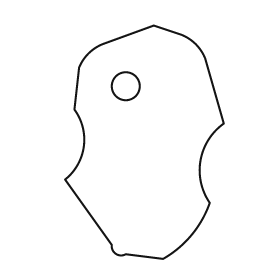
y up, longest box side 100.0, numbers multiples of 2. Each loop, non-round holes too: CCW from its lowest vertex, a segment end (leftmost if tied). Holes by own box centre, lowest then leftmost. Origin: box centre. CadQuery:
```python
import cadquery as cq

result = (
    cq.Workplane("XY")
    .moveTo(8.0, -50.0)
    .threePointArc((20.0, -40.0), (28.0, -26.0))
    .threePointArc((24.0, -8.0), (34.0, 8.0))
    .lineTo(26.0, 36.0)
    .threePointArc((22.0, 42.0), (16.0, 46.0))
    .lineTo(4.0, 50.0)
    .lineTo(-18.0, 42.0)
    .threePointArc((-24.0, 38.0), (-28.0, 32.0))
    .lineTo(-30.0, 14.0)
    .threePointArc((-26.0, -2.0), (-34.0, -16.0))
    .lineTo(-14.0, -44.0)
    .threePointArc((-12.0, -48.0), (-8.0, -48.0))
    .close()
    .moveTo(-8.0, 24.0)
    .circle(6.0)
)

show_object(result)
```